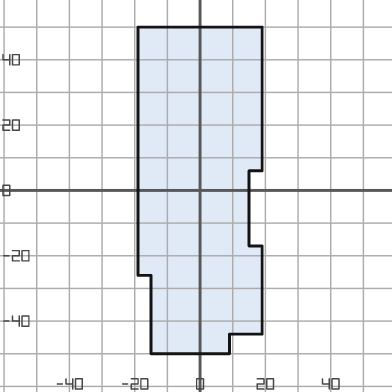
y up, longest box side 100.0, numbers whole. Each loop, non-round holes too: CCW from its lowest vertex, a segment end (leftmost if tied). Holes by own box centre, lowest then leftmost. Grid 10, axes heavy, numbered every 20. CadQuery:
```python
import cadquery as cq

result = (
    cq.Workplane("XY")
    .moveTo(-15.0, -50.0)
    .lineTo(9.0, -50.0)
    .lineTo(9.0, -44.0)
    .lineTo(19.0, -44.0)
    .lineTo(19.0, -17.0)
    .lineTo(15.0, -17.0)
    .lineTo(15.0, 6.0)
    .lineTo(19.0, 6.0)
    .lineTo(19.0, 50.0)
    .lineTo(-19.0, 50.0)
    .lineTo(-19.0, -26.0)
    .lineTo(-15.0, -26.0)
    .close()
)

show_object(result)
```